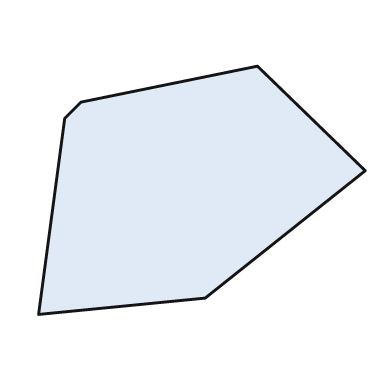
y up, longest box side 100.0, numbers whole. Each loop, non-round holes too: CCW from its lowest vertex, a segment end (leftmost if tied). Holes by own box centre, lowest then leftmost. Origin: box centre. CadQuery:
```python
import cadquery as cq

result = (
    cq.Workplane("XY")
    .moveTo(-50.0, -38.0)
    .lineTo(1.0, -33.0)
    .lineTo(50.0, 6.0)
    .lineTo(17.0, 38.0)
    .lineTo(-37.0, 27.0)
    .lineTo(-42.0, 22.0)
    .close()
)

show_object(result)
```